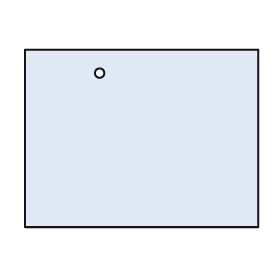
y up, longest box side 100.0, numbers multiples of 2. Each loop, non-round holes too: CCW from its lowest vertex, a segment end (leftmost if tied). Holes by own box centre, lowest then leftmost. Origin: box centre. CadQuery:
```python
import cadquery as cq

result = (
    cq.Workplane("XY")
    .moveTo(-50.0, -38.0)
    .lineTo(50.0, -38.0)
    .lineTo(50.0, 38.0)
    .lineTo(-50.0, 38.0)
    .close()
    .moveTo(-18.0, 28.0)
    .circle(2.0)
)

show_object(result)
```